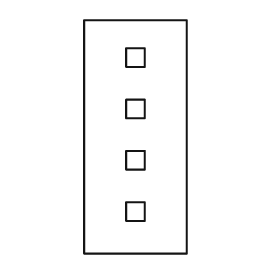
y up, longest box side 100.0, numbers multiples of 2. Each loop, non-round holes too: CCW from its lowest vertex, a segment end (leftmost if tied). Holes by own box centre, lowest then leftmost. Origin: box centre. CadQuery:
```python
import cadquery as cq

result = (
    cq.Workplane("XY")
    .moveTo(-22.0, -50.0)
    .lineTo(22.0, -50.0)
    .lineTo(22.0, 50.0)
    .lineTo(-22.0, 50.0)
    .close()
    .moveTo(-4.0, -36.0)
    .lineTo(4.0, -36.0)
    .lineTo(4.0, -28.0)
    .lineTo(-4.0, -28.0)
    .close()
    .moveTo(-4.0, -14.0)
    .lineTo(4.0, -14.0)
    .lineTo(4.0, -6.0)
    .lineTo(-4.0, -6.0)
    .close()
    .moveTo(-4.0, 8.0)
    .lineTo(4.0, 8.0)
    .lineTo(4.0, 16.0)
    .lineTo(-4.0, 16.0)
    .close()
    .moveTo(-4.0, 30.0)
    .lineTo(4.0, 30.0)
    .lineTo(4.0, 38.0)
    .lineTo(-4.0, 38.0)
    .close()
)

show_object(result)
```